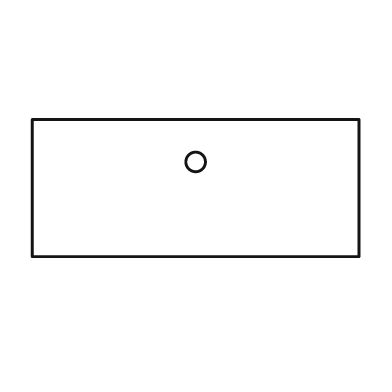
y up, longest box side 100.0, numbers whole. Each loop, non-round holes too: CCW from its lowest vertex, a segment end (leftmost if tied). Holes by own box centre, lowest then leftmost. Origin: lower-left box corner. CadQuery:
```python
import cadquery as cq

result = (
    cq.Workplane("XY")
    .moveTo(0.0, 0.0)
    .lineTo(100.0, 0.0)
    .lineTo(100.0, 42.0)
    .lineTo(0.0, 42.0)
    .close()
    .moveTo(50.0, 29.0)
    .circle(3.0)
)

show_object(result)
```